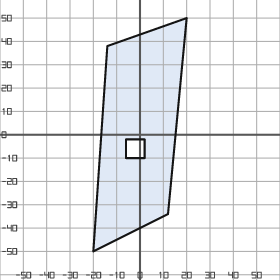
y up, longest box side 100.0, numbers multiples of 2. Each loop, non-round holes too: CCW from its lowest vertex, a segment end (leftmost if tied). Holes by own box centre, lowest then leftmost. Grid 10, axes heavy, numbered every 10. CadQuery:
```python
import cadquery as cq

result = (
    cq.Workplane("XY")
    .moveTo(-20.0, -50.0)
    .lineTo(12.0, -34.0)
    .lineTo(20.0, 50.0)
    .lineTo(-14.0, 38.0)
    .close()
    .moveTo(-6.0, -10.0)
    .lineTo(2.0, -10.0)
    .lineTo(2.0, -2.0)
    .lineTo(-6.0, -2.0)
    .close()
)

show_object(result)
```